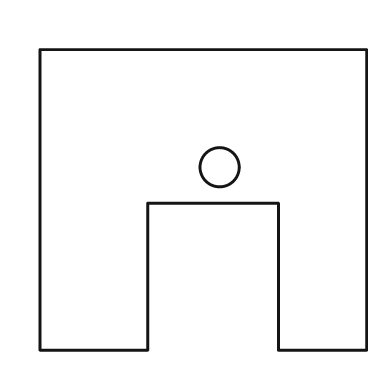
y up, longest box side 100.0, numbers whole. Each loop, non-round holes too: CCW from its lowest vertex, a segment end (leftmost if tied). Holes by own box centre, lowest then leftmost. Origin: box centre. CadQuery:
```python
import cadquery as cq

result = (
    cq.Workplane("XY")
    .moveTo(-50.0, -46.0)
    .lineTo(-17.0, -46.0)
    .lineTo(-17.0, -1.0)
    .lineTo(23.0, -1.0)
    .lineTo(23.0, -46.0)
    .lineTo(50.0, -46.0)
    .lineTo(50.0, 46.0)
    .lineTo(-50.0, 46.0)
    .close()
    .moveTo(5.0, 10.0)
    .circle(6.0)
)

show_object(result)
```